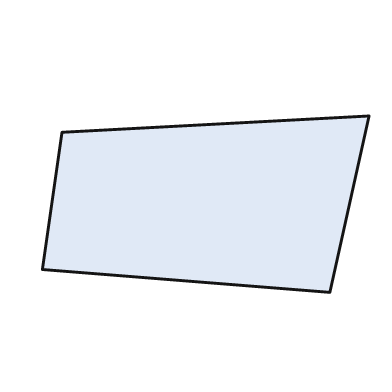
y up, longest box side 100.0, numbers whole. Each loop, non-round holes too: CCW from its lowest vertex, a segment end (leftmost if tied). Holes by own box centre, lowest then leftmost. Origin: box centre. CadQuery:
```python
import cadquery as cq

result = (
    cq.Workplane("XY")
    .moveTo(38.0, -27.0)
    .lineTo(50.0, 27.0)
    .lineTo(-44.0, 22.0)
    .lineTo(-50.0, -20.0)
    .close()
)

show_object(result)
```